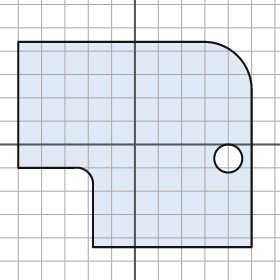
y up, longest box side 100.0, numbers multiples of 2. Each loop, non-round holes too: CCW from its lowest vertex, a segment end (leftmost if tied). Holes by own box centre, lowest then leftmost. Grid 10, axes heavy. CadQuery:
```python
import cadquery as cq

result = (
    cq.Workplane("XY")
    .moveTo(-18.0, -44.0)
    .lineTo(50.0, -44.0)
    .lineTo(50.0, 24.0)
    .threePointArc((44.0, 38.0), (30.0, 44.0))
    .lineTo(-50.0, 44.0)
    .lineTo(-50.0, -10.0)
    .lineTo(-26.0, -10.0)
    .threePointArc((-20.0, -12.0), (-18.0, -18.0))
    .close()
    .moveTo(40.0, -6.0)
    .circle(6.0)
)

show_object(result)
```